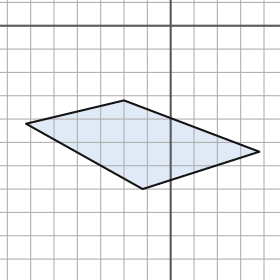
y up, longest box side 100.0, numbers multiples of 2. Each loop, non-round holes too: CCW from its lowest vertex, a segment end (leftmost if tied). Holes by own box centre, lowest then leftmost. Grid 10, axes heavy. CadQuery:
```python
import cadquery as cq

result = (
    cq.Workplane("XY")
    .moveTo(-12.0, -70.0)
    .lineTo(38.0, -54.0)
    .lineTo(-20.0, -32.0)
    .lineTo(-62.0, -42.0)
    .close()
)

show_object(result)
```